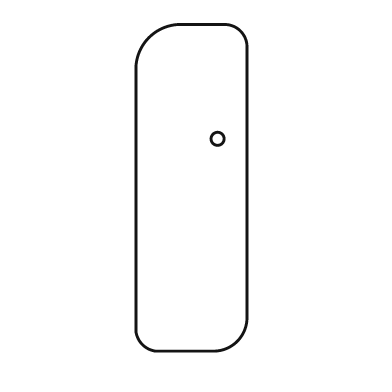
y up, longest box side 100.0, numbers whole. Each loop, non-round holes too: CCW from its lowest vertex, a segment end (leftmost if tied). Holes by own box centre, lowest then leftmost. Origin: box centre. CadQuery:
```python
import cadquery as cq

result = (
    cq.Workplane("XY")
    .moveTo(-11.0, -50.0)
    .lineTo(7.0, -50.0)
    .threePointArc((14.0, -47.0), (17.0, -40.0))
    .lineTo(17.0, 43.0)
    .threePointArc((15.0, 48.0), (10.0, 50.0))
    .lineTo(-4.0, 50.0)
    .threePointArc((-13.0, 46.0), (-17.0, 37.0))
    .lineTo(-17.0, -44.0)
    .threePointArc((-15.0, -48.0), (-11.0, -50.0))
    .close()
    .moveTo(8.0, 15.0)
    .circle(2.0)
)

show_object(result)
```